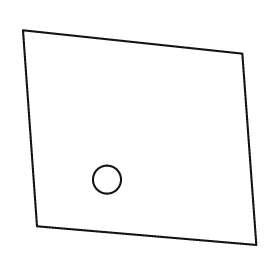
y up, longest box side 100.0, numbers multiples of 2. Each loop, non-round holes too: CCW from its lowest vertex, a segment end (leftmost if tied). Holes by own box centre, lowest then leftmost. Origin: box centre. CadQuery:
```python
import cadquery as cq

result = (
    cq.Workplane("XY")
    .moveTo(50.0, -46.0)
    .lineTo(44.0, 36.0)
    .lineTo(-50.0, 46.0)
    .lineTo(-44.0, -38.0)
    .close()
    .moveTo(-14.0, -18.0)
    .circle(6.0)
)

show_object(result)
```